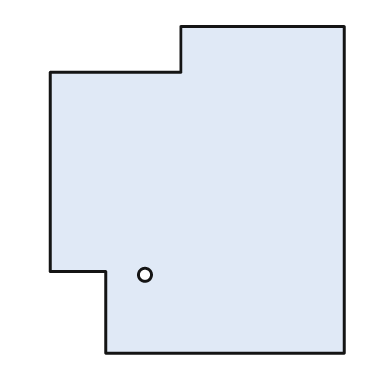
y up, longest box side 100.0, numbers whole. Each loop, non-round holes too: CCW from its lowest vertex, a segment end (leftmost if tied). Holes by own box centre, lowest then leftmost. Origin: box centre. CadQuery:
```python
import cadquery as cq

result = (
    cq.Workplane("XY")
    .moveTo(-28.0, -50.0)
    .lineTo(45.0, -50.0)
    .lineTo(45.0, 50.0)
    .lineTo(-5.0, 50.0)
    .lineTo(-5.0, 36.0)
    .lineTo(-45.0, 36.0)
    .lineTo(-45.0, -25.0)
    .lineTo(-28.0, -25.0)
    .close()
    .moveTo(-16.0, -26.0)
    .circle(2.0)
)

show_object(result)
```